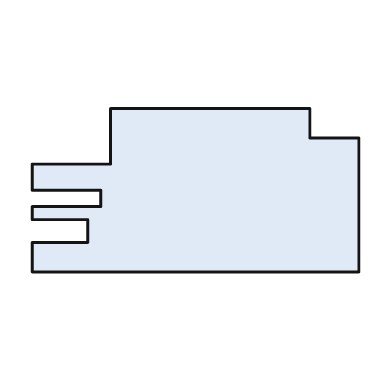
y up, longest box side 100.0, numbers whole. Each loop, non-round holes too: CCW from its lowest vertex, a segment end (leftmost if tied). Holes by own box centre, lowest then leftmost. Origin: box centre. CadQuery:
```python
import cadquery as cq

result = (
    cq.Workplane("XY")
    .moveTo(-50.0, -25.0)
    .lineTo(50.0, -25.0)
    .lineTo(50.0, 16.0)
    .lineTo(35.0, 16.0)
    .lineTo(35.0, 25.0)
    .lineTo(-26.0, 25.0)
    .lineTo(-26.0, 8.0)
    .lineTo(-50.0, 8.0)
    .lineTo(-50.0, 0.0)
    .lineTo(-29.0, 0.0)
    .lineTo(-29.0, -5.0)
    .lineTo(-50.0, -5.0)
    .lineTo(-50.0, -9.0)
    .lineTo(-33.0, -9.0)
    .lineTo(-33.0, -16.0)
    .lineTo(-50.0, -16.0)
    .close()
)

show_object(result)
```